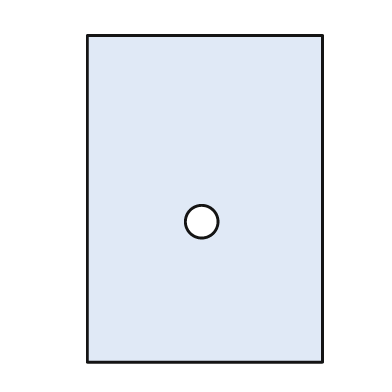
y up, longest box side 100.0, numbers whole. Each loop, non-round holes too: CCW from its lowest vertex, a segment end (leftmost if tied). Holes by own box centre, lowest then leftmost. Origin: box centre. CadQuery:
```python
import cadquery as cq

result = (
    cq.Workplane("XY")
    .moveTo(-36.0, -50.0)
    .lineTo(36.0, -50.0)
    .lineTo(36.0, 50.0)
    .lineTo(-36.0, 50.0)
    .close()
    .moveTo(-1.0, -7.0)
    .circle(5.0)
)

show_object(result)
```